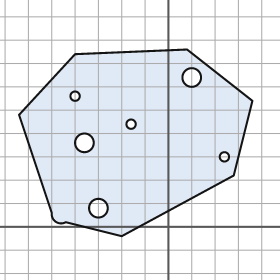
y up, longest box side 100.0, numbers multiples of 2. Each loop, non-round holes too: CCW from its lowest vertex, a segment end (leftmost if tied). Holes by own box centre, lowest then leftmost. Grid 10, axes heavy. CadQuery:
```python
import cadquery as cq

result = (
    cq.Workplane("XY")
    .moveTo(-20.0, -4.0)
    .lineTo(28.0, 22.0)
    .lineTo(36.0, 54.0)
    .lineTo(8.0, 76.0)
    .lineTo(-40.0, 74.0)
    .lineTo(-64.0, 48.0)
    .lineTo(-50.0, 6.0)
    .threePointArc((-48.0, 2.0), (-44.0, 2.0))
    .close()
    .moveTo(-30.0, 8.0)
    .circle(4.0)
    .moveTo(24.0, 30.0)
    .circle(2.0)
    .moveTo(-36.0, 36.0)
    .circle(4.0)
    .moveTo(-16.0, 44.0)
    .circle(2.0)
    .moveTo(-40.0, 56.0)
    .circle(2.0)
    .moveTo(10.0, 64.0)
    .circle(4.0)
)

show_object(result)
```